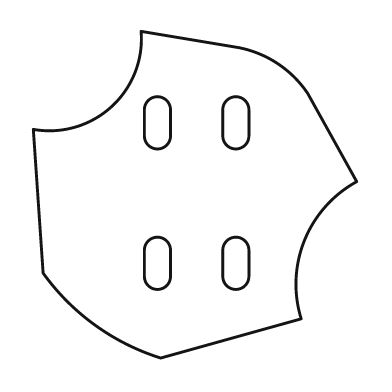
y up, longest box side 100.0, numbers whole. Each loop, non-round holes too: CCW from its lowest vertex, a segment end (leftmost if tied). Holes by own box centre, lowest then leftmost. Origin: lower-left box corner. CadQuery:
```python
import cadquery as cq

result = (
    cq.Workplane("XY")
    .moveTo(39.0, 0.0)
    .lineTo(82.0, 12.0)
    .threePointArc((83.0, 36.0), (99.0, 54.0))
    .lineTo(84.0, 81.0)
    .threePointArc((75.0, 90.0), (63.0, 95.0))
    .lineTo(33.0, 100.0)
    .threePointArc((24.0, 77.0), (0.0, 70.0))
    .lineTo(3.0, 26.0)
    .threePointArc((19.0, 10.0), (39.0, 0.0))
    .close()
    .moveTo(34.0, 25.0)
    .threePointArc((38.0, 21.0), (42.0, 25.0))
    .lineTo(42.0, 33.0)
    .threePointArc((38.0, 37.0), (34.0, 33.0))
    .close()
    .moveTo(58.0, 25.0)
    .threePointArc((62.0, 21.0), (66.0, 25.0))
    .lineTo(66.0, 33.0)
    .threePointArc((62.0, 37.0), (58.0, 33.0))
    .close()
    .moveTo(34.0, 68.0)
    .threePointArc((38.0, 64.0), (42.0, 68.0))
    .lineTo(42.0, 76.0)
    .threePointArc((38.0, 80.0), (34.0, 76.0))
    .close()
    .moveTo(58.0, 68.0)
    .threePointArc((62.0, 64.0), (66.0, 68.0))
    .lineTo(66.0, 76.0)
    .threePointArc((62.0, 80.0), (58.0, 76.0))
    .close()
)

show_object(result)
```